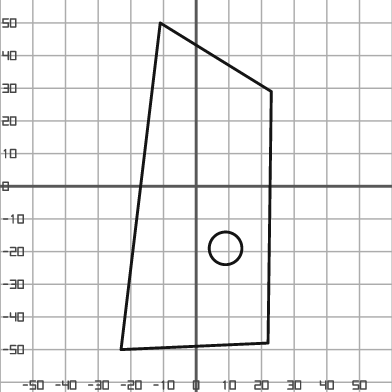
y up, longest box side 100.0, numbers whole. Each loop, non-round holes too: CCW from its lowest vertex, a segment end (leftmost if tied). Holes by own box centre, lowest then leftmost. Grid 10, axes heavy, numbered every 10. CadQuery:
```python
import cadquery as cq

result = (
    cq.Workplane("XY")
    .moveTo(-23.0, -50.0)
    .lineTo(22.0, -48.0)
    .lineTo(23.0, 29.0)
    .lineTo(-11.0, 50.0)
    .close()
    .moveTo(9.0, -19.0)
    .circle(5.0)
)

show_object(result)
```